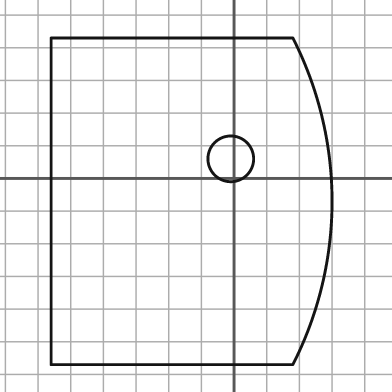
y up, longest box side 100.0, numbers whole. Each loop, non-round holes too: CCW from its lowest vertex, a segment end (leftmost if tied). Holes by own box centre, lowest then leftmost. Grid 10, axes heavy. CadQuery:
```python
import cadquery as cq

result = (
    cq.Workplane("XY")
    .moveTo(-56.0, -57.0)
    .lineTo(18.0, -57.0)
    .threePointArc((30.0, -7.0), (18.0, 43.0))
    .lineTo(-56.0, 43.0)
    .close()
    .moveTo(-1.0, 6.0)
    .circle(7.0)
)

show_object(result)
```